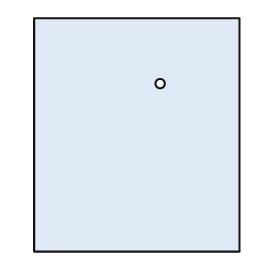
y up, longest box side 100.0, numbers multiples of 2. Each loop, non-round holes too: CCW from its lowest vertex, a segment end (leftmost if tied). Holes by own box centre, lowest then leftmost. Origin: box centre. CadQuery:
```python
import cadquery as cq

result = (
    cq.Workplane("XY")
    .moveTo(-44.0, -50.0)
    .lineTo(44.0, -50.0)
    .lineTo(44.0, 50.0)
    .lineTo(-44.0, 50.0)
    .close()
    .moveTo(10.0, 22.0)
    .circle(2.0)
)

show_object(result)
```